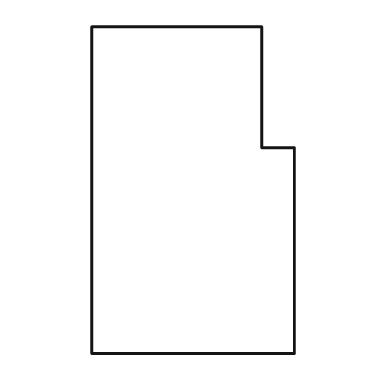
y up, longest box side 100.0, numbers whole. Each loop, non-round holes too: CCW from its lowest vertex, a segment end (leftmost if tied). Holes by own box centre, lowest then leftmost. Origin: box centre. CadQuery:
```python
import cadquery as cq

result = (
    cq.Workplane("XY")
    .moveTo(-31.0, -50.0)
    .lineTo(31.0, -50.0)
    .lineTo(31.0, 13.0)
    .lineTo(21.0, 13.0)
    .lineTo(21.0, 50.0)
    .lineTo(-31.0, 50.0)
    .close()
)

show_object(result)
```